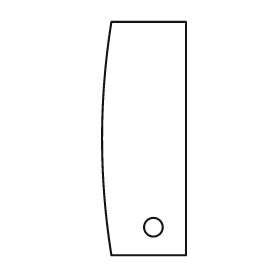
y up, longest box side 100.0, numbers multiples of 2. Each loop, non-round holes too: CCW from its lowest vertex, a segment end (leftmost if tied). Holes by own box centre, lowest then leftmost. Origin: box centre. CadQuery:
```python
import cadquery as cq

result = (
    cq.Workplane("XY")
    .moveTo(-14.0, -50.0)
    .lineTo(18.0, -50.0)
    .lineTo(18.0, 50.0)
    .lineTo(-14.0, 50.0)
    .threePointArc((-18.0, 0.0), (-14.0, -50.0))
    .close()
    .moveTo(4.0, -38.0)
    .circle(4.0)
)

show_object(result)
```